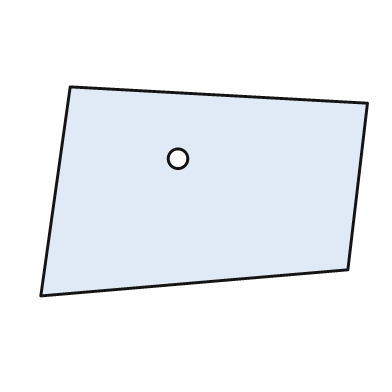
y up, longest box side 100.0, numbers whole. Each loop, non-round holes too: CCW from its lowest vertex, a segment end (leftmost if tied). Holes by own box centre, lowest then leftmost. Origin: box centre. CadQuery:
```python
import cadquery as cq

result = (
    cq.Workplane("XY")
    .moveTo(-50.0, -32.0)
    .lineTo(44.0, -24.0)
    .lineTo(50.0, 27.0)
    .lineTo(-41.0, 32.0)
    .close()
    .moveTo(-8.0, 10.0)
    .circle(3.0)
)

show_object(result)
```